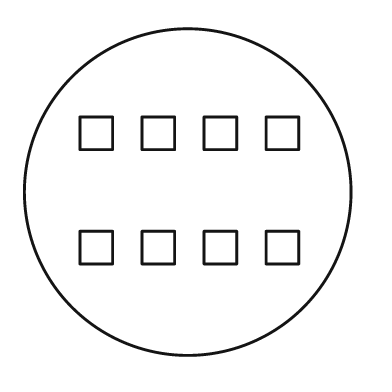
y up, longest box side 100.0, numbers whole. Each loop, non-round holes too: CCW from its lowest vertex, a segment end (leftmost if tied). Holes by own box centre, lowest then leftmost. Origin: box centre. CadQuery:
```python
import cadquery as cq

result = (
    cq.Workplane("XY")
    .moveTo(0.0, 0.0)
    .circle(50.0)
    .moveTo(-33.0, -22.0)
    .lineTo(-23.0, -22.0)
    .lineTo(-23.0, -12.0)
    .lineTo(-33.0, -12.0)
    .close()
    .moveTo(-14.0, -22.0)
    .lineTo(-4.0, -22.0)
    .lineTo(-4.0, -12.0)
    .lineTo(-14.0, -12.0)
    .close()
    .moveTo(5.0, -22.0)
    .lineTo(15.0, -22.0)
    .lineTo(15.0, -12.0)
    .lineTo(5.0, -12.0)
    .close()
    .moveTo(24.0, -22.0)
    .lineTo(34.0, -22.0)
    .lineTo(34.0, -12.0)
    .lineTo(24.0, -12.0)
    .close()
    .moveTo(-33.0, 13.0)
    .lineTo(-23.0, 13.0)
    .lineTo(-23.0, 23.0)
    .lineTo(-33.0, 23.0)
    .close()
    .moveTo(-14.0, 13.0)
    .lineTo(-4.0, 13.0)
    .lineTo(-4.0, 23.0)
    .lineTo(-14.0, 23.0)
    .close()
    .moveTo(5.0, 13.0)
    .lineTo(15.0, 13.0)
    .lineTo(15.0, 23.0)
    .lineTo(5.0, 23.0)
    .close()
    .moveTo(24.0, 13.0)
    .lineTo(34.0, 13.0)
    .lineTo(34.0, 23.0)
    .lineTo(24.0, 23.0)
    .close()
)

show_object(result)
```